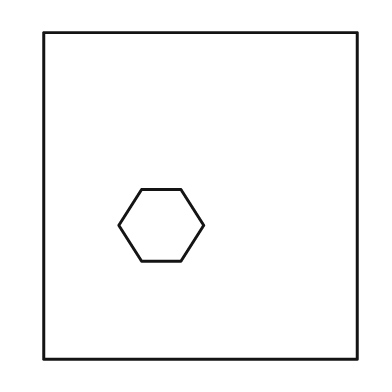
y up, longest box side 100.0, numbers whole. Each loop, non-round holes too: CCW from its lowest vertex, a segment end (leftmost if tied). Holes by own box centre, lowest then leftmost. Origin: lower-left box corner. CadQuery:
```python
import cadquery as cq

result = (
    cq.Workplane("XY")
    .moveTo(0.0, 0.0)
    .lineTo(96.0, 0.0)
    .lineTo(96.0, 100.0)
    .lineTo(0.0, 100.0)
    .close()
    .moveTo(30.0, 30.0)
    .lineTo(42.0, 30.0)
    .lineTo(49.0, 41.0)
    .lineTo(42.0, 52.0)
    .lineTo(30.0, 52.0)
    .lineTo(23.0, 41.0)
    .close()
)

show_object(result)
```